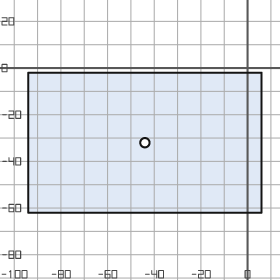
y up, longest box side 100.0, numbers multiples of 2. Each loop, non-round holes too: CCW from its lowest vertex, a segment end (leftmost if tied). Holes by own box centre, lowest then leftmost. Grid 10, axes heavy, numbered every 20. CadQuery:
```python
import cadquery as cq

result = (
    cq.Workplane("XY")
    .moveTo(-94.0, -62.0)
    .lineTo(6.0, -62.0)
    .lineTo(6.0, -2.0)
    .lineTo(-94.0, -2.0)
    .close()
    .moveTo(-44.0, -32.0)
    .circle(2.0)
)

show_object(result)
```